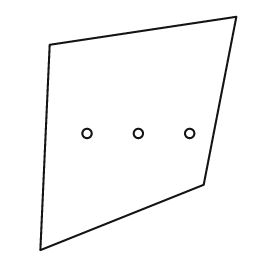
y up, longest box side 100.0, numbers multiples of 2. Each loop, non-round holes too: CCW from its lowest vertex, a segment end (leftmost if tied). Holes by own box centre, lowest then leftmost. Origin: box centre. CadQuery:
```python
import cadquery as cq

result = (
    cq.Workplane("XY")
    .moveTo(-42.0, -50.0)
    .lineTo(28.0, -22.0)
    .lineTo(42.0, 50.0)
    .lineTo(-38.0, 38.0)
    .close()
    .moveTo(-22.0, 0.0)
    .circle(2.0)
    .moveTo(0.0, 0.0)
    .circle(2.0)
    .moveTo(22.0, 0.0)
    .circle(2.0)
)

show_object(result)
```